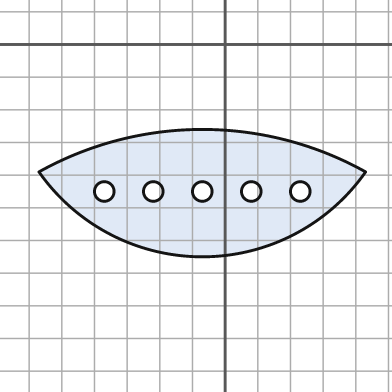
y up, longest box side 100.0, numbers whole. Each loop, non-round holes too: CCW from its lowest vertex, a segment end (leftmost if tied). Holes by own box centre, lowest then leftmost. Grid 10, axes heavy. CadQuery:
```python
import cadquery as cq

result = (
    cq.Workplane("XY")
    .moveTo(-57.0, -39.0)
    .threePointArc((-7.0, -65.0), (43.0, -39.0))
    .threePointArc((-7.0, -26.0), (-57.0, -39.0))
    .close()
    .moveTo(-37.0, -45.0)
    .circle(3.0)
    .moveTo(-22.0, -45.0)
    .circle(3.0)
    .moveTo(-7.0, -45.0)
    .circle(3.0)
    .moveTo(8.0, -45.0)
    .circle(3.0)
    .moveTo(23.0, -45.0)
    .circle(3.0)
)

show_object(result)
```